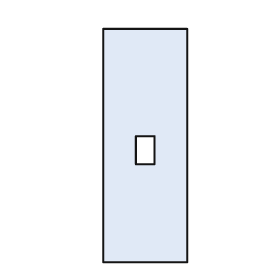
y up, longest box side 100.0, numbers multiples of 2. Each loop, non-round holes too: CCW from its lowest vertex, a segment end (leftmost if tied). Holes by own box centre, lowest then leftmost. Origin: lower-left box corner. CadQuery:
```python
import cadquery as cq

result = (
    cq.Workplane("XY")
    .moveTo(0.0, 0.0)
    .lineTo(36.0, 0.0)
    .lineTo(36.0, 100.0)
    .lineTo(0.0, 100.0)
    .close()
    .moveTo(14.0, 42.0)
    .lineTo(22.0, 42.0)
    .lineTo(22.0, 54.0)
    .lineTo(14.0, 54.0)
    .close()
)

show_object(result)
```